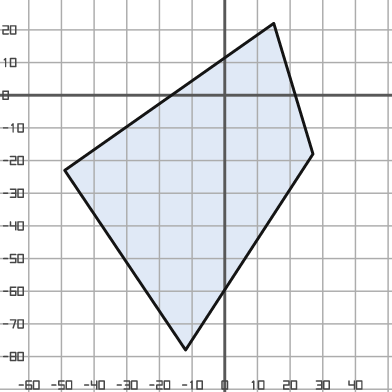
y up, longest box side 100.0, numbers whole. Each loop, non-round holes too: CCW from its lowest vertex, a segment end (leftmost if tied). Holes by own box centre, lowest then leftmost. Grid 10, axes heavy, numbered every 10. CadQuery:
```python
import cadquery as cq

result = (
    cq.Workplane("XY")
    .moveTo(-12.0, -78.0)
    .lineTo(27.0, -18.0)
    .lineTo(15.0, 22.0)
    .lineTo(-49.0, -23.0)
    .close()
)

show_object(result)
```